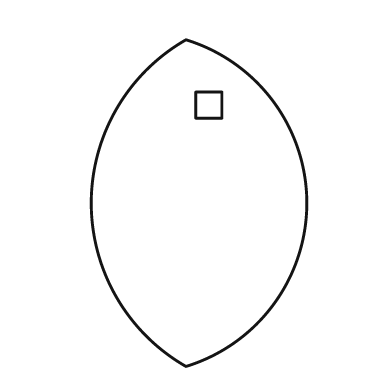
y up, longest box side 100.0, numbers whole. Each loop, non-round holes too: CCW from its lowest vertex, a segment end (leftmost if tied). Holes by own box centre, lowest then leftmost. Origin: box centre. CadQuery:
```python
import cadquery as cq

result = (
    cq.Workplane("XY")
    .moveTo(-4.0, -50.0)
    .threePointArc((33.0, 0.0), (-4.0, 50.0))
    .threePointArc((-33.0, 0.0), (-4.0, -50.0))
    .close()
    .moveTo(-1.0, 26.0)
    .lineTo(7.0, 26.0)
    .lineTo(7.0, 34.0)
    .lineTo(-1.0, 34.0)
    .close()
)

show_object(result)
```